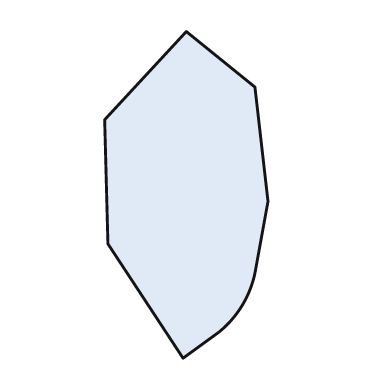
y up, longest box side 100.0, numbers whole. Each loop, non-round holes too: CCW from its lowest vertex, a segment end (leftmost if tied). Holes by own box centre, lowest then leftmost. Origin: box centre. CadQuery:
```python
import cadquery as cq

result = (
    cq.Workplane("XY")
    .moveTo(-1.0, -50.0)
    .lineTo(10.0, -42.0)
    .threePointArc((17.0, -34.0), (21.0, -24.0))
    .lineTo(25.0, -2.0)
    .lineTo(21.0, 33.0)
    .lineTo(0.0, 50.0)
    .lineTo(-25.0, 23.0)
    .lineTo(-24.0, -15.0)
    .close()
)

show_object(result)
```